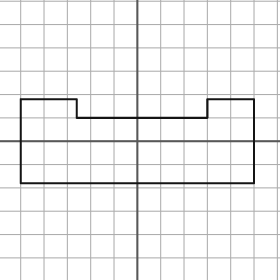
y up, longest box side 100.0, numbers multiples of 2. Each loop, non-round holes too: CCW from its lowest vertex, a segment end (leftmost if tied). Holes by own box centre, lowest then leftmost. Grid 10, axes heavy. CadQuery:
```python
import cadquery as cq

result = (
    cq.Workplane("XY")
    .moveTo(-50.0, -18.0)
    .lineTo(50.0, -18.0)
    .lineTo(50.0, 18.0)
    .lineTo(30.0, 18.0)
    .lineTo(30.0, 10.0)
    .lineTo(-26.0, 10.0)
    .lineTo(-26.0, 18.0)
    .lineTo(-50.0, 18.0)
    .close()
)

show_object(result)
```